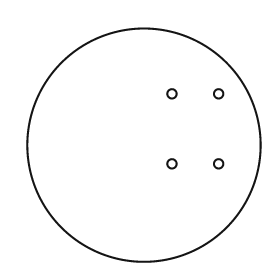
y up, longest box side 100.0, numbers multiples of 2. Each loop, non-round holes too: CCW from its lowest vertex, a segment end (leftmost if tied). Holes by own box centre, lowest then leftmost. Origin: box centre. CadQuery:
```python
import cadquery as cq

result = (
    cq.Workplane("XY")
    .moveTo(0.0, 0.0)
    .circle(50.0)
    .moveTo(12.0, -8.0)
    .circle(2.0)
    .moveTo(32.0, -8.0)
    .circle(2.0)
    .moveTo(12.0, 22.0)
    .circle(2.0)
    .moveTo(32.0, 22.0)
    .circle(2.0)
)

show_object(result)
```